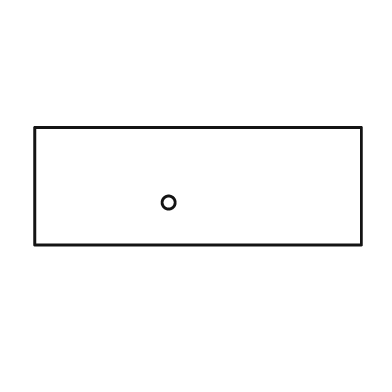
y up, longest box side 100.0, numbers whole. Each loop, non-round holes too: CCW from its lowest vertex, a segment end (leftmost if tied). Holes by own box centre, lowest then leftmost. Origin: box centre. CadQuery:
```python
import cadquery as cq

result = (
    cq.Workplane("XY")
    .moveTo(-50.0, -18.0)
    .lineTo(50.0, -18.0)
    .lineTo(50.0, 18.0)
    .lineTo(-50.0, 18.0)
    .close()
    .moveTo(-9.0, -5.0)
    .circle(2.0)
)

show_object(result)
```